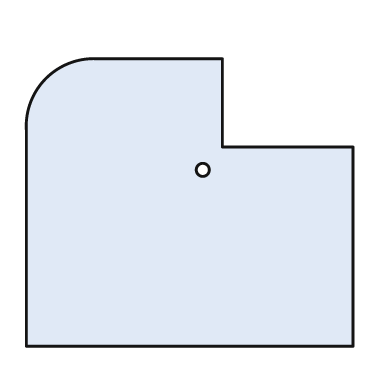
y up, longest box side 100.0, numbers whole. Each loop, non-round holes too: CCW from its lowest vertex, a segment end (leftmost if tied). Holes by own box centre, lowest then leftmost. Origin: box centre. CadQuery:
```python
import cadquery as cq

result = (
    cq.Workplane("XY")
    .moveTo(-50.0, -44.0)
    .lineTo(50.0, -44.0)
    .lineTo(50.0, 17.0)
    .lineTo(10.0, 17.0)
    .lineTo(10.0, 44.0)
    .lineTo(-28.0, 44.0)
    .threePointArc((-44.0, 38.0), (-50.0, 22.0))
    .close()
    .moveTo(4.0, 10.0)
    .circle(2.0)
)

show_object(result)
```